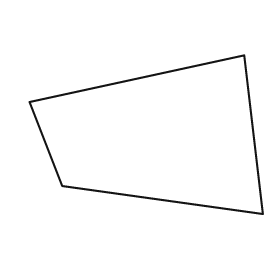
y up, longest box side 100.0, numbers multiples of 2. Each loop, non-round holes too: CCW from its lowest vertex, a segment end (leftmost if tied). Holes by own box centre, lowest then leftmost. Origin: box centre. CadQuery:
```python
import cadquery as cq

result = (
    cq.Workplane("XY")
    .moveTo(50.0, -34.0)
    .lineTo(42.0, 34.0)
    .lineTo(-50.0, 14.0)
    .lineTo(-36.0, -22.0)
    .close()
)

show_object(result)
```